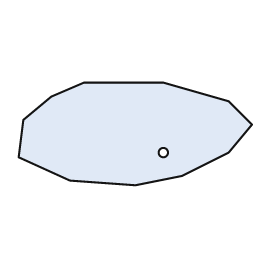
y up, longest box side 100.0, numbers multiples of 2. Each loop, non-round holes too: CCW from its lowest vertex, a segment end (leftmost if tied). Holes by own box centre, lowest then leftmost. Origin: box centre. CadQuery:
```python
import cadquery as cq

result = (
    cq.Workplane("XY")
    .moveTo(0.0, -22.0)
    .lineTo(20.0, -18.0)
    .lineTo(40.0, -8.0)
    .lineTo(50.0, 4.0)
    .lineTo(40.0, 14.0)
    .lineTo(12.0, 22.0)
    .lineTo(-22.0, 22.0)
    .lineTo(-36.0, 16.0)
    .lineTo(-48.0, 6.0)
    .lineTo(-50.0, -10.0)
    .lineTo(-28.0, -20.0)
    .close()
    .moveTo(12.0, -8.0)
    .circle(2.0)
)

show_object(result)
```